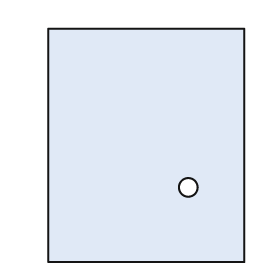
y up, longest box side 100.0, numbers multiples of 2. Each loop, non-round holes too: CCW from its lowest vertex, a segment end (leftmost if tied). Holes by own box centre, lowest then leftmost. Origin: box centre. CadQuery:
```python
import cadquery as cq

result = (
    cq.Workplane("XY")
    .moveTo(-42.0, -50.0)
    .lineTo(42.0, -50.0)
    .lineTo(42.0, 50.0)
    .lineTo(-42.0, 50.0)
    .close()
    .moveTo(18.0, -18.0)
    .circle(4.0)
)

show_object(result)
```